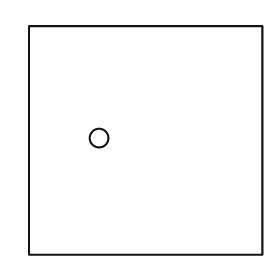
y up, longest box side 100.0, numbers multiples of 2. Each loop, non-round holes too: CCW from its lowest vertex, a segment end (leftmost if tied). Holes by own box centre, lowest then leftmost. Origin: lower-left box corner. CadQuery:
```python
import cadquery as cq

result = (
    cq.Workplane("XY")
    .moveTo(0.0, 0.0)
    .lineTo(100.0, 0.0)
    .lineTo(100.0, 98.0)
    .lineTo(0.0, 98.0)
    .close()
    .moveTo(30.0, 50.0)
    .circle(4.0)
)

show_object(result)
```